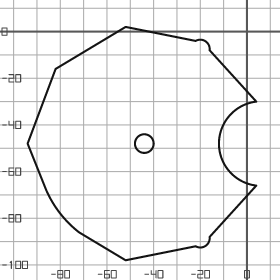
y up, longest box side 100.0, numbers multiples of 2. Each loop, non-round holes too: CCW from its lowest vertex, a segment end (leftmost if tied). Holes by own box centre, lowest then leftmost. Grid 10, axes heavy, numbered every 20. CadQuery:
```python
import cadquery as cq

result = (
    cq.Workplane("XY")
    .moveTo(-52.0, -98.0)
    .lineTo(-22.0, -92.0)
    .threePointArc((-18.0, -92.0), (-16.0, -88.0))
    .lineTo(4.0, -66.0)
    .threePointArc((-12.0, -48.0), (4.0, -30.0))
    .lineTo(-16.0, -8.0)
    .threePointArc((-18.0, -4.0), (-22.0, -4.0))
    .lineTo(-52.0, 2.0)
    .lineTo(-82.0, -16.0)
    .lineTo(-94.0, -48.0)
    .lineTo(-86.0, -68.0)
    .threePointArc((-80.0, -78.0), (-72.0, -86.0))
    .close()
    .moveTo(-44.0, -48.0)
    .circle(4.0)
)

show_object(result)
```